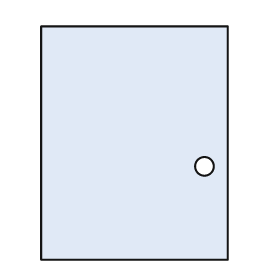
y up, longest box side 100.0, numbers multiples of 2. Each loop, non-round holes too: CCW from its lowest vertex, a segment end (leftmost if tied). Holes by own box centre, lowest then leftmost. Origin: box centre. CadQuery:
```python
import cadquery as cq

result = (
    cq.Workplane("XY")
    .moveTo(-40.0, -50.0)
    .lineTo(40.0, -50.0)
    .lineTo(40.0, 50.0)
    .lineTo(-40.0, 50.0)
    .close()
    .moveTo(30.0, -10.0)
    .circle(4.0)
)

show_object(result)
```